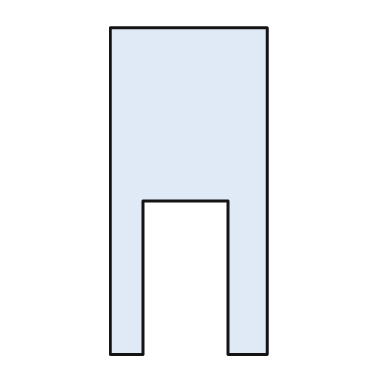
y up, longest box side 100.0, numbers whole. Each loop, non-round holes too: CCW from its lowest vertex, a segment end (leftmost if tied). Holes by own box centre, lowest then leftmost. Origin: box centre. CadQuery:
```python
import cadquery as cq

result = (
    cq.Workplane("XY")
    .moveTo(-24.0, -50.0)
    .lineTo(-14.0, -50.0)
    .lineTo(-14.0, -3.0)
    .lineTo(12.0, -3.0)
    .lineTo(12.0, -50.0)
    .lineTo(24.0, -50.0)
    .lineTo(24.0, 50.0)
    .lineTo(-24.0, 50.0)
    .close()
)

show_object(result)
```